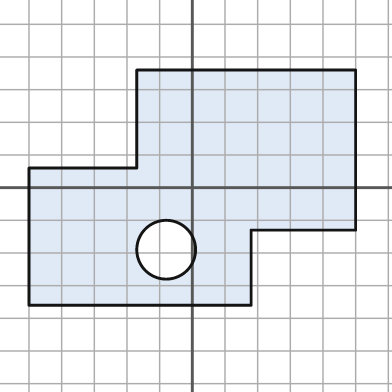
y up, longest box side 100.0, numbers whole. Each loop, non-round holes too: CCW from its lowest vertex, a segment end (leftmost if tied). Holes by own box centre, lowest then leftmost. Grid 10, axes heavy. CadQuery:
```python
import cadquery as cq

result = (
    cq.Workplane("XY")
    .moveTo(-50.0, -36.0)
    .lineTo(18.0, -36.0)
    .lineTo(18.0, -13.0)
    .lineTo(50.0, -13.0)
    .lineTo(50.0, 36.0)
    .lineTo(-17.0, 36.0)
    .lineTo(-17.0, 6.0)
    .lineTo(-50.0, 6.0)
    .close()
    .moveTo(-8.0, -19.0)
    .circle(9.0)
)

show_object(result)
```